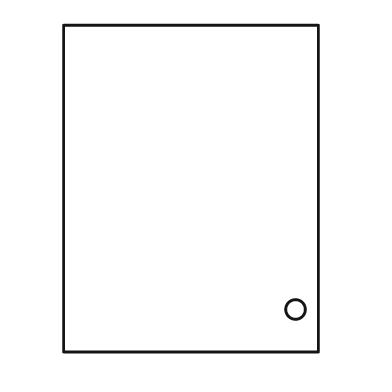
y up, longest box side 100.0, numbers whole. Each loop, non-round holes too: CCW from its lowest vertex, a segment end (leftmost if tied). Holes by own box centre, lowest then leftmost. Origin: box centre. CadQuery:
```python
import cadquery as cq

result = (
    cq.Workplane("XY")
    .moveTo(-39.0, -50.0)
    .lineTo(39.0, -50.0)
    .lineTo(39.0, 50.0)
    .lineTo(-39.0, 50.0)
    .close()
    .moveTo(32.0, -37.0)
    .circle(3.0)
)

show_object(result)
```